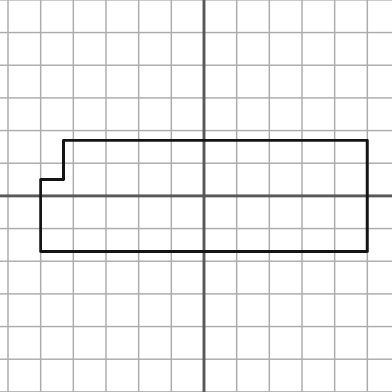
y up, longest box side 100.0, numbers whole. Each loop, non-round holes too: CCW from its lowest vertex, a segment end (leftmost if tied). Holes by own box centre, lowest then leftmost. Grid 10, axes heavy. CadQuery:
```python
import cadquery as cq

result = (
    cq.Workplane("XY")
    .moveTo(-50.0, -17.0)
    .lineTo(50.0, -17.0)
    .lineTo(50.0, 17.0)
    .lineTo(-43.0, 17.0)
    .lineTo(-43.0, 5.0)
    .lineTo(-50.0, 5.0)
    .close()
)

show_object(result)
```